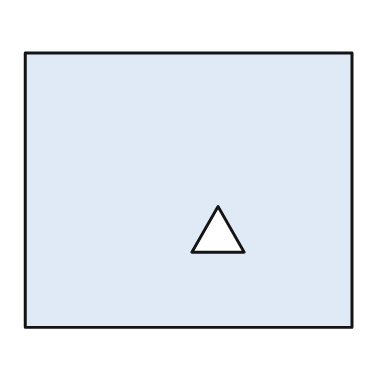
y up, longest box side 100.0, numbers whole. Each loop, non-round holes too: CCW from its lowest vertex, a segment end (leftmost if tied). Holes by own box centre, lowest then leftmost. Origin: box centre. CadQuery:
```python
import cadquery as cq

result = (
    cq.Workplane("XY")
    .moveTo(-50.0, -42.0)
    .lineTo(50.0, -42.0)
    .lineTo(50.0, 42.0)
    .lineTo(-50.0, 42.0)
    .close()
    .moveTo(1.0, -19.0)
    .lineTo(17.0, -19.0)
    .lineTo(9.0, -5.0)
    .close()
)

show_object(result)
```